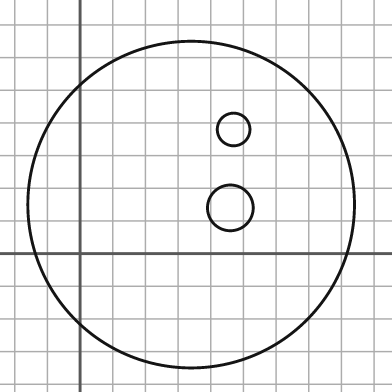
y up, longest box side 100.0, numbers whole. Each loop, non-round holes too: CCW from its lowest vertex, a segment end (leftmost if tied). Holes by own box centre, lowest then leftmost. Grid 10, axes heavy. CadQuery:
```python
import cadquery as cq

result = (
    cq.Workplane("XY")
    .moveTo(34.0, 15.0)
    .circle(50.0)
    .moveTo(46.0, 14.0)
    .circle(7.0)
    .moveTo(47.0, 38.0)
    .circle(5.0)
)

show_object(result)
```